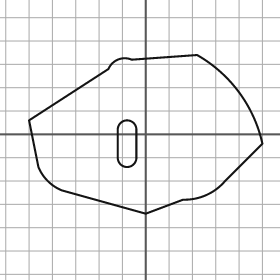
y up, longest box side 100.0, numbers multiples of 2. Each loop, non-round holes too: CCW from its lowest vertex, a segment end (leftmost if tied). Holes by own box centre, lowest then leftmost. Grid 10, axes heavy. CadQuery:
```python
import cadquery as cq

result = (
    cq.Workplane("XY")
    .moveTo(0.0, -34.0)
    .lineTo(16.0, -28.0)
    .threePointArc((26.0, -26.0), (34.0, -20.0))
    .lineTo(50.0, -4.0)
    .threePointArc((40.0, 18.0), (22.0, 34.0))
    .lineTo(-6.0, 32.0)
    .threePointArc((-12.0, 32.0), (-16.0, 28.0))
    .lineTo(-50.0, 6.0)
    .lineTo(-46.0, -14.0)
    .threePointArc((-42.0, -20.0), (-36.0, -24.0))
    .close()
    .moveTo(-12.0, -10.0)
    .threePointArc((-8.0, -14.0), (-4.0, -10.0))
    .lineTo(-4.0, 2.0)
    .threePointArc((-8.0, 6.0), (-12.0, 2.0))
    .close()
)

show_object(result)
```